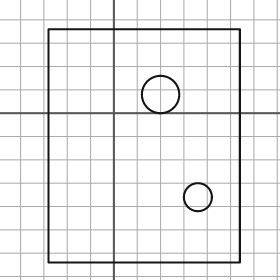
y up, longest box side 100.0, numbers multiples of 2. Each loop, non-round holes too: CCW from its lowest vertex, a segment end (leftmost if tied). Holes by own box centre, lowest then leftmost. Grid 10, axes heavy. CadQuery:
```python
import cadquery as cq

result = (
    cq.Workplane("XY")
    .moveTo(-28.0, -64.0)
    .lineTo(54.0, -64.0)
    .lineTo(54.0, 36.0)
    .lineTo(-28.0, 36.0)
    .close()
    .moveTo(36.0, -36.0)
    .circle(6.0)
    .moveTo(20.0, 8.0)
    .circle(8.0)
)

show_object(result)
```